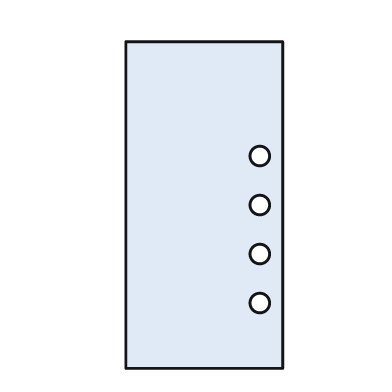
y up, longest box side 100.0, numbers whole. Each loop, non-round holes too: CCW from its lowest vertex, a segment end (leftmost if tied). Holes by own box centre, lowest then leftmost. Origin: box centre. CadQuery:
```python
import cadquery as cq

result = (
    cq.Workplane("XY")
    .moveTo(-24.0, -50.0)
    .lineTo(24.0, -50.0)
    .lineTo(24.0, 50.0)
    .lineTo(-24.0, 50.0)
    .close()
    .moveTo(17.0, -30.0)
    .circle(3.0)
    .moveTo(17.0, -15.0)
    .circle(3.0)
    .moveTo(17.0, 0.0)
    .circle(3.0)
    .moveTo(17.0, 15.0)
    .circle(3.0)
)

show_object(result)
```